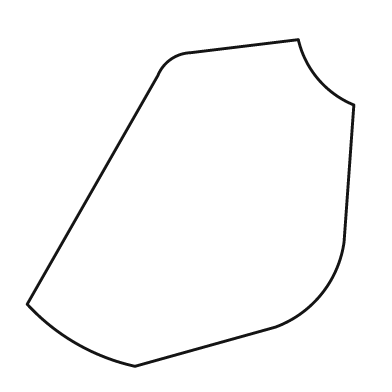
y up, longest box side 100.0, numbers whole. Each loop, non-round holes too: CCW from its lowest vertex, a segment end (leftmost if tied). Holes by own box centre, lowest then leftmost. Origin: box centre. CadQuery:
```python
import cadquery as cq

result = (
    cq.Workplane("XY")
    .moveTo(-17.0, -50.0)
    .lineTo(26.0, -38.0)
    .threePointArc((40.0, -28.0), (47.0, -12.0))
    .lineTo(50.0, 30.0)
    .threePointArc((39.0, 38.0), (33.0, 50.0))
    .lineTo(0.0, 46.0)
    .threePointArc((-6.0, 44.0), (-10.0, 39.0))
    .lineTo(-50.0, -31.0)
    .threePointArc((-35.0, -43.0), (-17.0, -50.0))
    .close()
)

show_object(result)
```